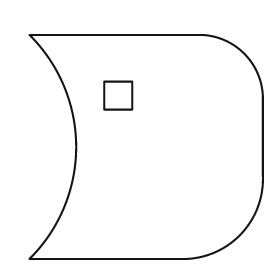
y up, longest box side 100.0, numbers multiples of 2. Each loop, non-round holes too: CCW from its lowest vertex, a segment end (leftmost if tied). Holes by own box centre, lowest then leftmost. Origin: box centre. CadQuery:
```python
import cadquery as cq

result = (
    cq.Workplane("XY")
    .moveTo(-50.0, -48.0)
    .lineTo(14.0, -48.0)
    .threePointArc((40.0, -38.0), (50.0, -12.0))
    .lineTo(50.0, 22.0)
    .threePointArc((42.0, 40.0), (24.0, 48.0))
    .lineTo(-50.0, 48.0)
    .threePointArc((-30.0, 0.0), (-50.0, -48.0))
    .close()
    .moveTo(-18.0, 16.0)
    .lineTo(-6.0, 16.0)
    .lineTo(-6.0, 28.0)
    .lineTo(-18.0, 28.0)
    .close()
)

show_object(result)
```